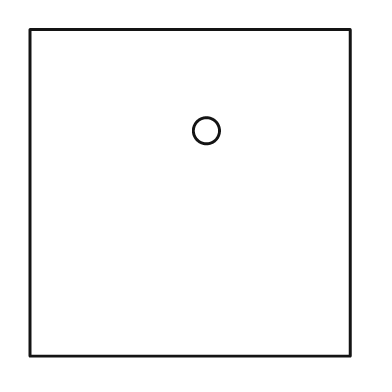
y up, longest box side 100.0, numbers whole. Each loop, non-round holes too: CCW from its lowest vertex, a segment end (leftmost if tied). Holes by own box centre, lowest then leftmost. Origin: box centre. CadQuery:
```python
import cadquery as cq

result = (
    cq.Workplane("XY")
    .moveTo(-49.0, -50.0)
    .lineTo(49.0, -50.0)
    .lineTo(49.0, 50.0)
    .lineTo(-49.0, 50.0)
    .close()
    .moveTo(5.0, 19.0)
    .circle(4.0)
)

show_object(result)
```